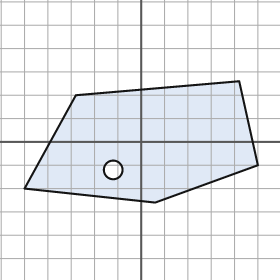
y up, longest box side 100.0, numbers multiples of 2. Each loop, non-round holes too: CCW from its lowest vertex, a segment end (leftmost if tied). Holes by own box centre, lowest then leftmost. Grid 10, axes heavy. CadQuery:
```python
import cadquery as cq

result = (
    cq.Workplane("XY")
    .moveTo(6.0, -26.0)
    .lineTo(50.0, -10.0)
    .lineTo(42.0, 26.0)
    .lineTo(-28.0, 20.0)
    .lineTo(-50.0, -20.0)
    .close()
    .moveTo(-12.0, -12.0)
    .circle(4.0)
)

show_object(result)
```